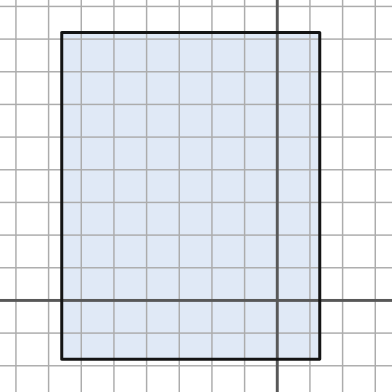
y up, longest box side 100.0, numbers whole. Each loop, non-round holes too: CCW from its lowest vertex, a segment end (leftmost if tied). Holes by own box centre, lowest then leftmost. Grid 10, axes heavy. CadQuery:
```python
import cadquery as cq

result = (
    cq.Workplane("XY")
    .moveTo(-66.0, -18.0)
    .lineTo(13.0, -18.0)
    .lineTo(13.0, 82.0)
    .lineTo(-66.0, 82.0)
    .close()
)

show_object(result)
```